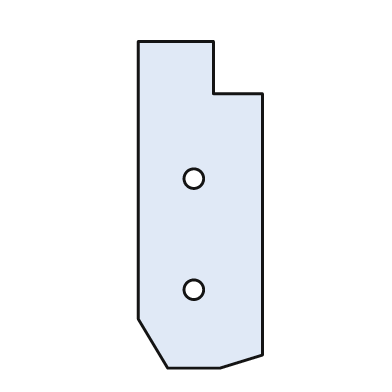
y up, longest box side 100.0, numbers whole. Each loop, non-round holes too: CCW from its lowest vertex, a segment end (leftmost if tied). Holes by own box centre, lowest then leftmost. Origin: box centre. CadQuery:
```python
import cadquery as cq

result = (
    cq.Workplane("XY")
    .moveTo(-10.0, -50.0)
    .lineTo(6.0, -50.0)
    .lineTo(19.0, -46.0)
    .lineTo(19.0, 34.0)
    .lineTo(4.0, 34.0)
    .lineTo(4.0, 50.0)
    .lineTo(-19.0, 50.0)
    .lineTo(-19.0, -35.0)
    .close()
    .moveTo(-2.0, -26.0)
    .circle(3.0)
    .moveTo(-2.0, 8.0)
    .circle(3.0)
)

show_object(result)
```